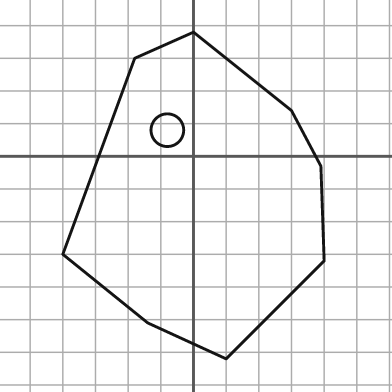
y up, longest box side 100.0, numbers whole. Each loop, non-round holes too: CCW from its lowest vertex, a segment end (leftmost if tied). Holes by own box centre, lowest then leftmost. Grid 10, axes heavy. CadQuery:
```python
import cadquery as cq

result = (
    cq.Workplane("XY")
    .moveTo(10.0, -62.0)
    .lineTo(40.0, -32.0)
    .lineTo(39.0, -3.0)
    .lineTo(30.0, 14.0)
    .lineTo(0.0, 38.0)
    .lineTo(-18.0, 30.0)
    .lineTo(-40.0, -30.0)
    .lineTo(-14.0, -51.0)
    .close()
    .moveTo(-8.0, 8.0)
    .circle(5.0)
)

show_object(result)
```